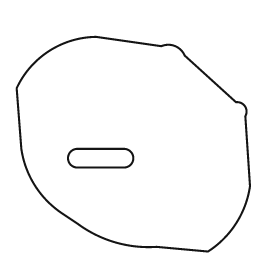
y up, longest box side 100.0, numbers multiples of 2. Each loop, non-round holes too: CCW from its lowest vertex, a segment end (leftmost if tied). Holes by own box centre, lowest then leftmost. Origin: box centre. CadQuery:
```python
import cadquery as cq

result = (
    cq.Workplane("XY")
    .moveTo(32.0, -46.0)
    .threePointArc((44.0, -34.0), (50.0, -18.0))
    .lineTo(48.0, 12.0)
    .threePointArc((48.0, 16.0), (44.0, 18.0))
    .lineTo(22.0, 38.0)
    .threePointArc((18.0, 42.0), (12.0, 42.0))
    .lineTo(-16.0, 46.0)
    .threePointArc((-36.0, 40.0), (-50.0, 24.0))
    .lineTo(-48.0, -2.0)
    .threePointArc((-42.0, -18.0), (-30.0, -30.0))
    .lineTo(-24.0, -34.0)
    .threePointArc((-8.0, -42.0), (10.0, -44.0))
    .close()
    .moveTo(-24.0, -10.0)
    .lineTo(-4.0, -10.0)
    .threePointArc((0.0, -6.0), (-4.0, -2.0))
    .lineTo(-24.0, -2.0)
    .threePointArc((-28.0, -6.0), (-24.0, -10.0))
    .close()
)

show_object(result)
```